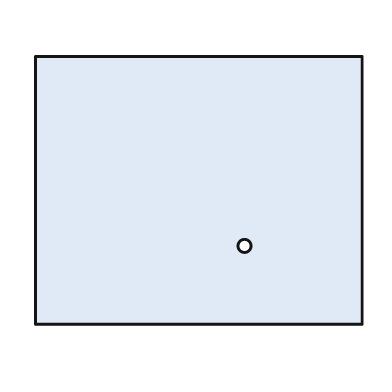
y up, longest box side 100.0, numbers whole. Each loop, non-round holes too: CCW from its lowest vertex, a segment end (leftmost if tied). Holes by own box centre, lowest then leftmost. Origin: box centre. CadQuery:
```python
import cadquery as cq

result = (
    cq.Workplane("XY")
    .moveTo(-50.0, -41.0)
    .lineTo(50.0, -41.0)
    .lineTo(50.0, 41.0)
    .lineTo(-50.0, 41.0)
    .close()
    .moveTo(14.0, -17.0)
    .circle(2.0)
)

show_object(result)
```